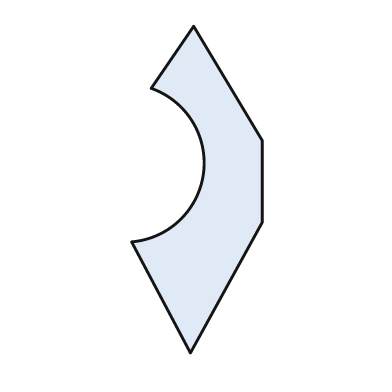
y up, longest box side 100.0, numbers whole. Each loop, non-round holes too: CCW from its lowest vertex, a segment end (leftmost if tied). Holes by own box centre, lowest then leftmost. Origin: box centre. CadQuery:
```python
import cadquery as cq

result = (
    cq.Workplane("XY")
    .moveTo(-2.0, -50.0)
    .lineTo(20.0, -10.0)
    .lineTo(20.0, 15.0)
    .lineTo(-1.0, 50.0)
    .lineTo(-14.0, 31.0)
    .threePointArc((2.0, 5.0), (-20.0, -16.0))
    .close()
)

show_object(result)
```